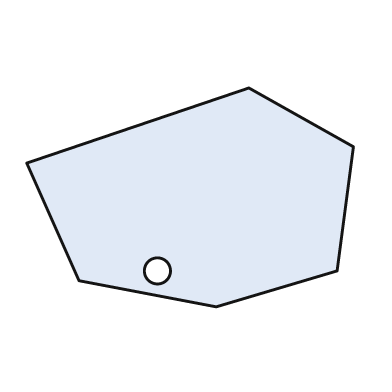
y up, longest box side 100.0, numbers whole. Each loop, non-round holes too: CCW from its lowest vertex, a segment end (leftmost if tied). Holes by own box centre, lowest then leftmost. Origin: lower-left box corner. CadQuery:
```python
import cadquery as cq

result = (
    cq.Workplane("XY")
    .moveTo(58.0, 0.0)
    .lineTo(95.0, 11.0)
    .lineTo(100.0, 49.0)
    .lineTo(68.0, 67.0)
    .lineTo(0.0, 44.0)
    .lineTo(16.0, 8.0)
    .close()
    .moveTo(40.0, 11.0)
    .circle(4.0)
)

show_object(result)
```